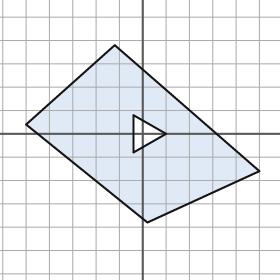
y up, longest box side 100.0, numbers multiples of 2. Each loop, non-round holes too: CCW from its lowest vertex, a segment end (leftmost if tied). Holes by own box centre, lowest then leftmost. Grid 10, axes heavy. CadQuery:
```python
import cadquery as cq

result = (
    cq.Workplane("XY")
    .moveTo(2.0, -38.0)
    .lineTo(50.0, -16.0)
    .lineTo(-12.0, 38.0)
    .lineTo(-50.0, 4.0)
    .close()
    .moveTo(-4.0, -8.0)
    .lineTo(10.0, 0.0)
    .lineTo(-4.0, 8.0)
    .close()
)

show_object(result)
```